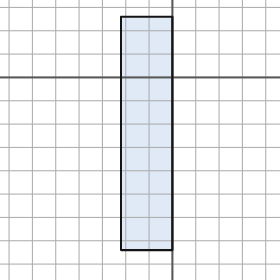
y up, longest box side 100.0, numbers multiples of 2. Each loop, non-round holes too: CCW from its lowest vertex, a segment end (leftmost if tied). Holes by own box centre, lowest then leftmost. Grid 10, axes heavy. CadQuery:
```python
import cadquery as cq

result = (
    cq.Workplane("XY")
    .moveTo(-22.0, -74.0)
    .lineTo(0.0, -74.0)
    .lineTo(0.0, 26.0)
    .lineTo(-22.0, 26.0)
    .close()
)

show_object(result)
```